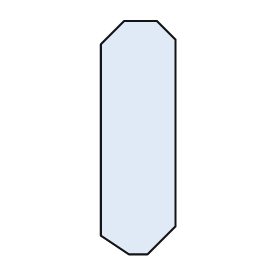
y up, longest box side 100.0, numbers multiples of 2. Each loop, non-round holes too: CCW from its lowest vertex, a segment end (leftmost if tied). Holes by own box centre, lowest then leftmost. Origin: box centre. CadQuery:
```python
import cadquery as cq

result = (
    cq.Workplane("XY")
    .moveTo(-4.0, -50.0)
    .lineTo(4.0, -50.0)
    .lineTo(16.0, -38.0)
    .lineTo(16.0, 42.0)
    .lineTo(8.0, 50.0)
    .lineTo(-6.0, 50.0)
    .lineTo(-16.0, 40.0)
    .lineTo(-16.0, -42.0)
    .close()
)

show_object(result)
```